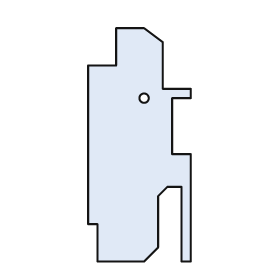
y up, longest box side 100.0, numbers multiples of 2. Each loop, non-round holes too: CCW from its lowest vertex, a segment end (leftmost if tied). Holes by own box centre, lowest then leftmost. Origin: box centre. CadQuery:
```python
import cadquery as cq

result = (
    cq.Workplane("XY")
    .moveTo(-18.0, -50.0)
    .lineTo(2.0, -50.0)
    .lineTo(8.0, -44.0)
    .lineTo(8.0, -22.0)
    .lineTo(12.0, -18.0)
    .lineTo(18.0, -18.0)
    .lineTo(18.0, -50.0)
    .lineTo(22.0, -50.0)
    .lineTo(22.0, -4.0)
    .lineTo(14.0, -4.0)
    .lineTo(14.0, 20.0)
    .lineTo(22.0, 20.0)
    .lineTo(22.0, 24.0)
    .lineTo(10.0, 24.0)
    .lineTo(10.0, 44.0)
    .lineTo(2.0, 50.0)
    .lineTo(-10.0, 50.0)
    .lineTo(-10.0, 34.0)
    .lineTo(-22.0, 34.0)
    .lineTo(-22.0, -34.0)
    .lineTo(-18.0, -34.0)
    .close()
    .moveTo(2.0, 20.0)
    .circle(2.0)
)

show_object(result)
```